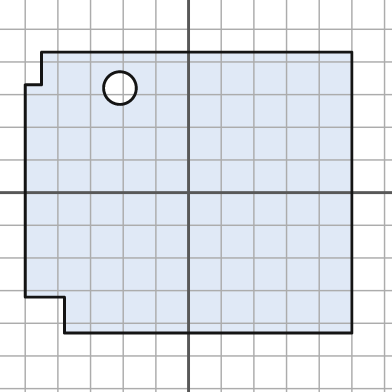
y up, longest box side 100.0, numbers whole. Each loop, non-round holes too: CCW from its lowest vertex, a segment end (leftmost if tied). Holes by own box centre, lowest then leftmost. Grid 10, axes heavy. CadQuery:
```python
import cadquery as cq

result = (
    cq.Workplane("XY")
    .moveTo(-38.0, -43.0)
    .lineTo(50.0, -43.0)
    .lineTo(50.0, 43.0)
    .lineTo(-45.0, 43.0)
    .lineTo(-45.0, 33.0)
    .lineTo(-50.0, 33.0)
    .lineTo(-50.0, -32.0)
    .lineTo(-38.0, -32.0)
    .close()
    .moveTo(-21.0, 32.0)
    .circle(5.0)
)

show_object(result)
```